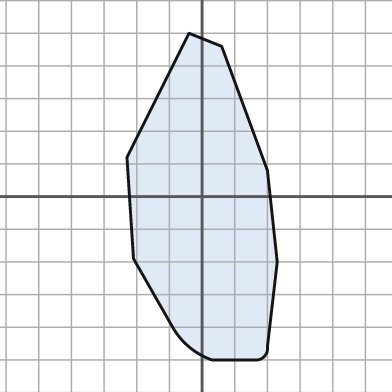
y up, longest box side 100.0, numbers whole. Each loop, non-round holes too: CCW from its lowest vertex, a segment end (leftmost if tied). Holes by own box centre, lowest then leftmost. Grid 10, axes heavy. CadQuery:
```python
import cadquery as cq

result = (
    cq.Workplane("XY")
    .moveTo(3.0, -50.0)
    .lineTo(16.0, -50.0)
    .threePointArc((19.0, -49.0), (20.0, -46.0))
    .lineTo(23.0, -20.0)
    .lineTo(20.0, 8.0)
    .lineTo(6.0, 46.0)
    .lineTo(-4.0, 50.0)
    .lineTo(-23.0, 12.0)
    .lineTo(-21.0, -19.0)
    .lineTo(-9.0, -40.0)
    .threePointArc((-4.0, -46.0), (3.0, -50.0))
    .close()
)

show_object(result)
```